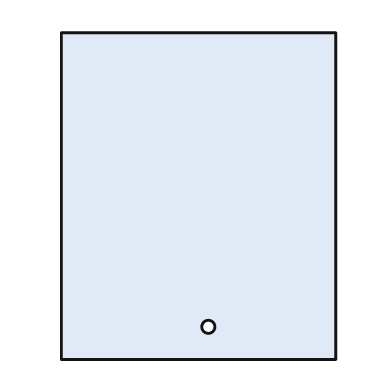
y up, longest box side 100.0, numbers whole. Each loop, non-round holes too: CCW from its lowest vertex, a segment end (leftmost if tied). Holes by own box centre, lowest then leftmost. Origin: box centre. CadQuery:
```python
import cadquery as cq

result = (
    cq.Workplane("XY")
    .moveTo(-42.0, -50.0)
    .lineTo(42.0, -50.0)
    .lineTo(42.0, 50.0)
    .lineTo(-42.0, 50.0)
    .close()
    .moveTo(3.0, -40.0)
    .circle(2.0)
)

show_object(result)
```